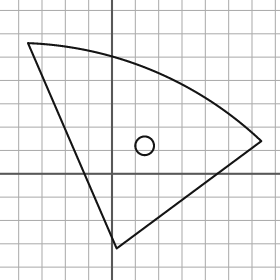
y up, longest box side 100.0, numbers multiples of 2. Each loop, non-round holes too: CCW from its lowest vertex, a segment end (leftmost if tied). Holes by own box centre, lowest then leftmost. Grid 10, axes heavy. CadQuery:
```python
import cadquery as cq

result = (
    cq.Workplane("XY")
    .moveTo(2.0, -32.0)
    .lineTo(64.0, 14.0)
    .threePointArc((18.0, 44.0), (-36.0, 56.0))
    .close()
    .moveTo(14.0, 12.0)
    .circle(4.0)
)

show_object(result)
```